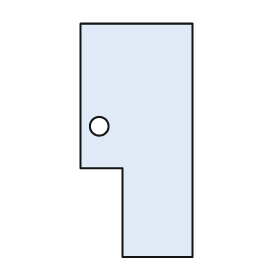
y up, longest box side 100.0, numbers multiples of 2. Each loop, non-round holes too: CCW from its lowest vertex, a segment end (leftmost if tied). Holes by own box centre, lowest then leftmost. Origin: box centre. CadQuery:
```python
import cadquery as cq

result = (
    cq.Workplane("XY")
    .moveTo(-6.0, -50.0)
    .lineTo(24.0, -50.0)
    .lineTo(24.0, 50.0)
    .lineTo(-24.0, 50.0)
    .lineTo(-24.0, -12.0)
    .lineTo(-6.0, -12.0)
    .close()
    .moveTo(-16.0, 6.0)
    .circle(4.0)
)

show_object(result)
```